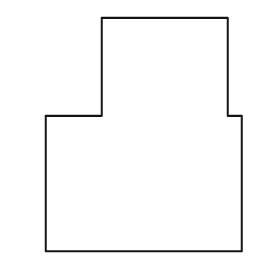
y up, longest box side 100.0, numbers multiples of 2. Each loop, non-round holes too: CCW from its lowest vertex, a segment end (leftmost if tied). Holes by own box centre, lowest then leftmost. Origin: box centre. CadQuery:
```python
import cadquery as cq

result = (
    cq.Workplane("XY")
    .moveTo(-42.0, -50.0)
    .lineTo(42.0, -50.0)
    .lineTo(42.0, 8.0)
    .lineTo(36.0, 8.0)
    .lineTo(36.0, 50.0)
    .lineTo(-18.0, 50.0)
    .lineTo(-18.0, 8.0)
    .lineTo(-42.0, 8.0)
    .close()
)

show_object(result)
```